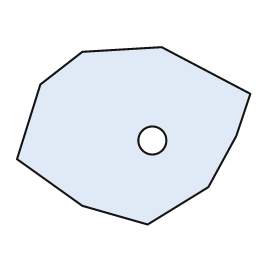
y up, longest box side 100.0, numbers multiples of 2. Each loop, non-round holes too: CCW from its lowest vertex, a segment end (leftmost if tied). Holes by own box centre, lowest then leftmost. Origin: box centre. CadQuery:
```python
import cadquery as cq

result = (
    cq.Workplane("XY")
    .moveTo(6.0, -38.0)
    .lineTo(32.0, -22.0)
    .lineTo(44.0, 0.0)
    .lineTo(50.0, 18.0)
    .lineTo(12.0, 38.0)
    .lineTo(-22.0, 36.0)
    .lineTo(-40.0, 22.0)
    .lineTo(-50.0, -10.0)
    .lineTo(-22.0, -30.0)
    .close()
    .moveTo(8.0, -2.0)
    .circle(6.0)
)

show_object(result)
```